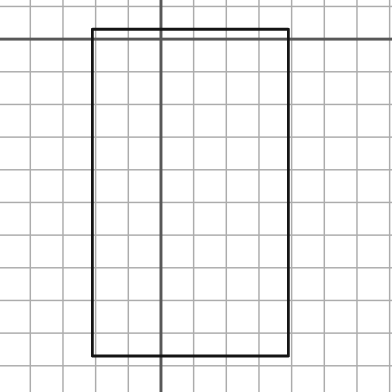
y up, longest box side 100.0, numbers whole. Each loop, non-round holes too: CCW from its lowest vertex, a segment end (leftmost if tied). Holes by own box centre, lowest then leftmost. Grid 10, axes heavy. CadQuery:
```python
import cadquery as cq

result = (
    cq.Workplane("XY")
    .moveTo(-21.0, -97.0)
    .lineTo(39.0, -97.0)
    .lineTo(39.0, 3.0)
    .lineTo(-21.0, 3.0)
    .close()
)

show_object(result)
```